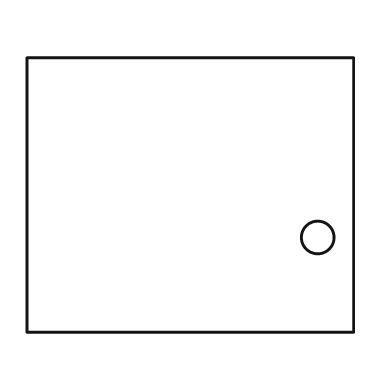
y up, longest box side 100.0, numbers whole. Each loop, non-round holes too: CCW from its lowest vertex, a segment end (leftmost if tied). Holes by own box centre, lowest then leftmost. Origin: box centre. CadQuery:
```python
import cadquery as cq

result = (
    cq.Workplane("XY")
    .moveTo(-50.0, -42.0)
    .lineTo(50.0, -42.0)
    .lineTo(50.0, 42.0)
    .lineTo(-50.0, 42.0)
    .close()
    .moveTo(39.0, -13.0)
    .circle(5.0)
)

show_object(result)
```